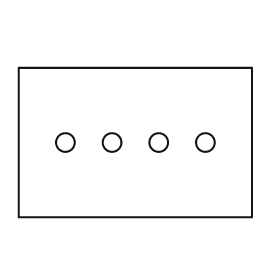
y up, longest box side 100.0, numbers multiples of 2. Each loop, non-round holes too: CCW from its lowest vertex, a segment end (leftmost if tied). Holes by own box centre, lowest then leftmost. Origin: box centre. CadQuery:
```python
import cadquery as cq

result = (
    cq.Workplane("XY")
    .moveTo(-50.0, -32.0)
    .lineTo(50.0, -32.0)
    .lineTo(50.0, 32.0)
    .lineTo(-50.0, 32.0)
    .close()
    .moveTo(-30.0, 0.0)
    .circle(4.0)
    .moveTo(-10.0, 0.0)
    .circle(4.0)
    .moveTo(10.0, 0.0)
    .circle(4.0)
    .moveTo(30.0, 0.0)
    .circle(4.0)
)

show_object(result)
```